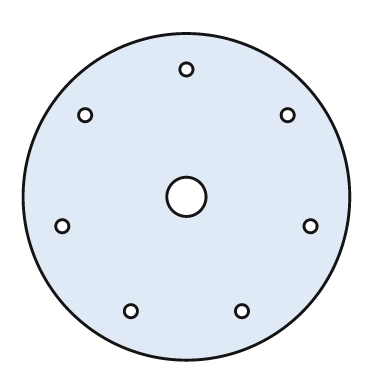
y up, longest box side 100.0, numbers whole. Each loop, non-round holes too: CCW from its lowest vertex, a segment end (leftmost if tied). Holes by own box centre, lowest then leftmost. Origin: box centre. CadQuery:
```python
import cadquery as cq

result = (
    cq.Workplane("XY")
    .moveTo(0.0, 0.0)
    .circle(50.0)
    .moveTo(-17.0, -35.0)
    .circle(2.0)
    .moveTo(17.0, -35.0)
    .circle(2.0)
    .moveTo(-38.0, -9.0)
    .circle(2.0)
    .moveTo(38.0, -9.0)
    .circle(2.0)
    .moveTo(0.0, 0.0)
    .circle(6.0)
    .moveTo(-31.0, 25.0)
    .circle(2.0)
    .moveTo(31.0, 25.0)
    .circle(2.0)
    .moveTo(0.0, 39.0)
    .circle(2.0)
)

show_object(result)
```